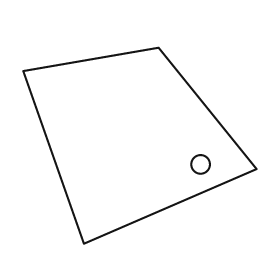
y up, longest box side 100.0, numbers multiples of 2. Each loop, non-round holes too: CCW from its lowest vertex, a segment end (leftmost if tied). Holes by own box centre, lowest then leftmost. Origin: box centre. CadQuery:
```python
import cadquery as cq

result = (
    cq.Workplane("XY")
    .moveTo(-24.0, -42.0)
    .lineTo(50.0, -10.0)
    .lineTo(8.0, 42.0)
    .lineTo(-50.0, 32.0)
    .close()
    .moveTo(26.0, -8.0)
    .circle(4.0)
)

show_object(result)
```